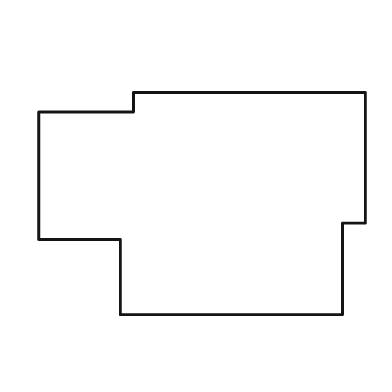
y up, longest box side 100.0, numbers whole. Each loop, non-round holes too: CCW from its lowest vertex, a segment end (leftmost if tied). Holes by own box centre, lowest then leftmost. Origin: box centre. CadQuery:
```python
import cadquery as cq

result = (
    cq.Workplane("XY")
    .moveTo(-25.0, -34.0)
    .lineTo(43.0, -34.0)
    .lineTo(43.0, -6.0)
    .lineTo(50.0, -6.0)
    .lineTo(50.0, 34.0)
    .lineTo(-21.0, 34.0)
    .lineTo(-21.0, 28.0)
    .lineTo(-50.0, 28.0)
    .lineTo(-50.0, -11.0)
    .lineTo(-25.0, -11.0)
    .close()
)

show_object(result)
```